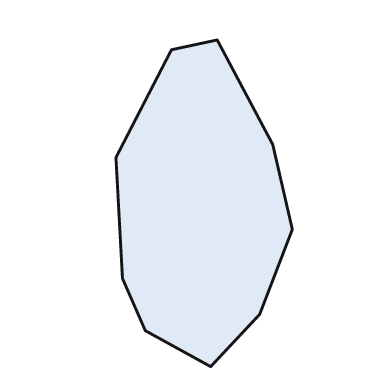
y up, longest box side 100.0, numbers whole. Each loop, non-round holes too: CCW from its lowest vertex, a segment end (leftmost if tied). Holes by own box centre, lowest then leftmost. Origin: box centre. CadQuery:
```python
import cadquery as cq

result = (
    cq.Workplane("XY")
    .moveTo(2.0, -50.0)
    .lineTo(17.0, -34.0)
    .lineTo(27.0, -8.0)
    .lineTo(21.0, 18.0)
    .lineTo(4.0, 50.0)
    .lineTo(-10.0, 47.0)
    .lineTo(-27.0, 14.0)
    .lineTo(-25.0, -23.0)
    .lineTo(-18.0, -39.0)
    .close()
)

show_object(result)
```